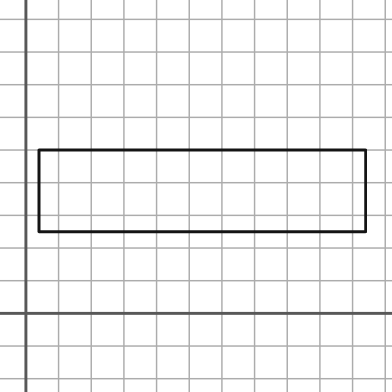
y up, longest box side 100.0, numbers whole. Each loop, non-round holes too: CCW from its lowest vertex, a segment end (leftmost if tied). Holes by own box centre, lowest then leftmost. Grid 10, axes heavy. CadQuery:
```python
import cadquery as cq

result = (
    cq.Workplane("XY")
    .moveTo(4.0, 25.0)
    .lineTo(104.0, 25.0)
    .lineTo(104.0, 50.0)
    .lineTo(4.0, 50.0)
    .close()
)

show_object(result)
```